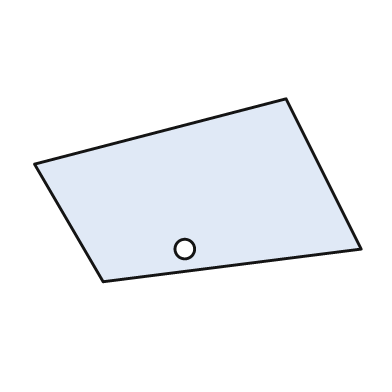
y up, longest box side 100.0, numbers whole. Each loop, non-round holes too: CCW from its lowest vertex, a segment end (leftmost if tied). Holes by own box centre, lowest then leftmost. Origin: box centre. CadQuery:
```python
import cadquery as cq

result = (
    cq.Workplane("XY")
    .moveTo(-29.0, -28.0)
    .lineTo(50.0, -18.0)
    .lineTo(27.0, 28.0)
    .lineTo(-50.0, 8.0)
    .close()
    .moveTo(-4.0, -18.0)
    .circle(3.0)
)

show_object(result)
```